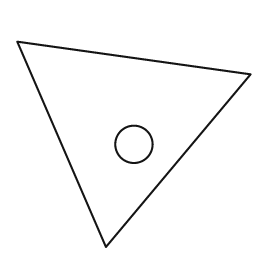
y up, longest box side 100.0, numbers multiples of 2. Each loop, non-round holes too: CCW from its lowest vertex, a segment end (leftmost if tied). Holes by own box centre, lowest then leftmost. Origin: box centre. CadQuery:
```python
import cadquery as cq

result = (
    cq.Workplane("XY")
    .moveTo(-12.0, -44.0)
    .lineTo(50.0, 30.0)
    .lineTo(-50.0, 44.0)
    .close()
    .moveTo(0.0, 0.0)
    .circle(8.0)
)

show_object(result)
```